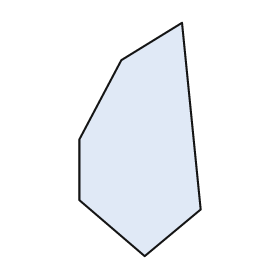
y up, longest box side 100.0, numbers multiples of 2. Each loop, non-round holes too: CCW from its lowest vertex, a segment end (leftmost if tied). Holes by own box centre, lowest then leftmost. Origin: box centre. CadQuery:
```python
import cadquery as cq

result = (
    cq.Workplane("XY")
    .moveTo(2.0, -50.0)
    .lineTo(26.0, -30.0)
    .lineTo(18.0, 50.0)
    .lineTo(-8.0, 34.0)
    .lineTo(-26.0, 0.0)
    .lineTo(-26.0, -26.0)
    .close()
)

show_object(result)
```